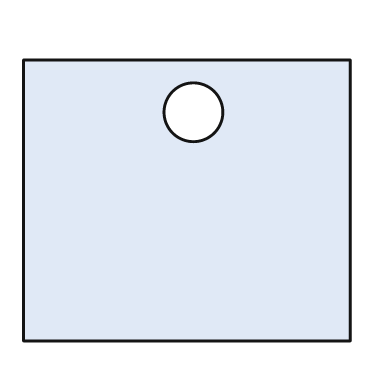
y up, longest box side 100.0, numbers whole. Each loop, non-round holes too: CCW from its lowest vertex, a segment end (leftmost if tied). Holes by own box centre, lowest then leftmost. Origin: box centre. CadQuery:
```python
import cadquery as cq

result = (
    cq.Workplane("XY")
    .moveTo(-50.0, -43.0)
    .lineTo(50.0, -43.0)
    .lineTo(50.0, 43.0)
    .lineTo(-50.0, 43.0)
    .close()
    .moveTo(2.0, 27.0)
    .circle(9.0)
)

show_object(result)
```